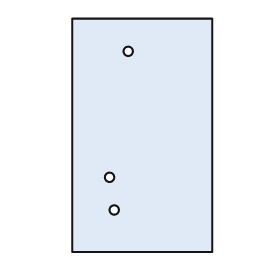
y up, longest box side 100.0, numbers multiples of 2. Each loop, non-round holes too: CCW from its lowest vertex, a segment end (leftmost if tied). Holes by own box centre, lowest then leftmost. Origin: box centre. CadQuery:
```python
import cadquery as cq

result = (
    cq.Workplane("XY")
    .moveTo(-30.0, -50.0)
    .lineTo(30.0, -50.0)
    .lineTo(30.0, 50.0)
    .lineTo(-30.0, 50.0)
    .close()
    .moveTo(-12.0, -32.0)
    .circle(2.0)
    .moveTo(-14.0, -18.0)
    .circle(2.0)
    .moveTo(-6.0, 36.0)
    .circle(2.0)
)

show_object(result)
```